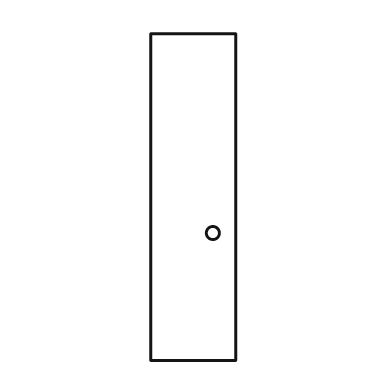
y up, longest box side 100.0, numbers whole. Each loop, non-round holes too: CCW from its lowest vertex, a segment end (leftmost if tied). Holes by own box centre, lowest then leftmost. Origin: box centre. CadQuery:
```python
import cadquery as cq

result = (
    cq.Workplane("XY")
    .moveTo(-13.0, -50.0)
    .lineTo(13.0, -50.0)
    .lineTo(13.0, 50.0)
    .lineTo(-13.0, 50.0)
    .close()
    .moveTo(6.0, -11.0)
    .circle(2.0)
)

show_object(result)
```